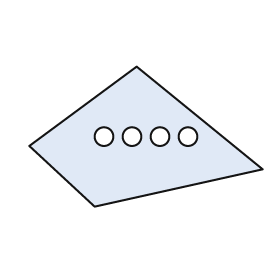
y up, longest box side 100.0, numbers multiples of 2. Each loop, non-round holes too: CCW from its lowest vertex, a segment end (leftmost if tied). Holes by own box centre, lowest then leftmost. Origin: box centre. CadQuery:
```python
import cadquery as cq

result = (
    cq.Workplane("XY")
    .moveTo(-22.0, -30.0)
    .lineTo(50.0, -14.0)
    .lineTo(-4.0, 30.0)
    .lineTo(-50.0, -4.0)
    .close()
    .moveTo(-18.0, 0.0)
    .circle(4.0)
    .moveTo(-6.0, 0.0)
    .circle(4.0)
    .moveTo(6.0, 0.0)
    .circle(4.0)
    .moveTo(18.0, 0.0)
    .circle(4.0)
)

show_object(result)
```